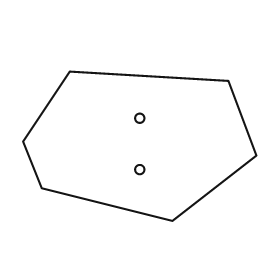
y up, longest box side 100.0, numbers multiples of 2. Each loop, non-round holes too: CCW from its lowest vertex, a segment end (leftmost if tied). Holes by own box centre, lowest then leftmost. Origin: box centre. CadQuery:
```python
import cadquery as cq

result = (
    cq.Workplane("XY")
    .moveTo(14.0, -32.0)
    .lineTo(50.0, -4.0)
    .lineTo(38.0, 28.0)
    .lineTo(-30.0, 32.0)
    .lineTo(-50.0, 2.0)
    .lineTo(-42.0, -18.0)
    .close()
    .moveTo(0.0, -10.0)
    .circle(2.0)
    .moveTo(0.0, 12.0)
    .circle(2.0)
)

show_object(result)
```